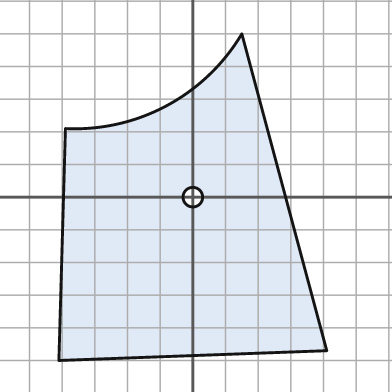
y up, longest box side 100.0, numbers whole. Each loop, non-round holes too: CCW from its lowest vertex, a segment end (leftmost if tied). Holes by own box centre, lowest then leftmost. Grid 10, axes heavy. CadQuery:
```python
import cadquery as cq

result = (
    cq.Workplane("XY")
    .moveTo(-41.0, -50.0)
    .lineTo(41.0, -47.0)
    .lineTo(15.0, 50.0)
    .threePointArc((-8.0, 28.0), (-39.0, 21.0))
    .close()
    .moveTo(0.0, 0.0)
    .circle(3.0)
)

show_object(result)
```